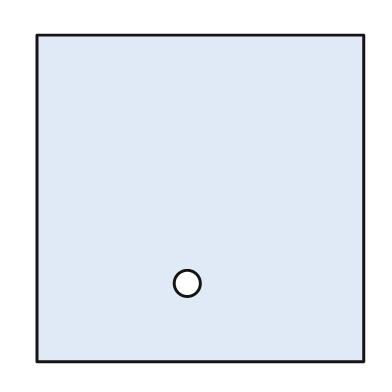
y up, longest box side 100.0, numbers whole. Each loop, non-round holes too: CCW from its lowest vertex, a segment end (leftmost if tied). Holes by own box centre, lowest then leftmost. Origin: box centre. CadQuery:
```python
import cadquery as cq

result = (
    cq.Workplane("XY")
    .moveTo(-50.0, -50.0)
    .lineTo(50.0, -50.0)
    .lineTo(50.0, 50.0)
    .lineTo(-50.0, 50.0)
    .close()
    .moveTo(-4.0, -26.0)
    .circle(4.0)
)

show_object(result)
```